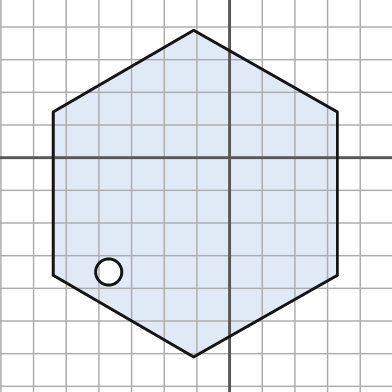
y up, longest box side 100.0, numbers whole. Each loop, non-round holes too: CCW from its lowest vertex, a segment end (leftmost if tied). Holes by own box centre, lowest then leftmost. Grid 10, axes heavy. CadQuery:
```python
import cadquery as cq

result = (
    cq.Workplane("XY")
    .moveTo(-11.0, -61.0)
    .lineTo(33.0, -36.0)
    .lineTo(33.0, 14.0)
    .lineTo(-11.0, 39.0)
    .lineTo(-54.0, 14.0)
    .lineTo(-54.0, -36.0)
    .close()
    .moveTo(-37.0, -35.0)
    .circle(4.0)
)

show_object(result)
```